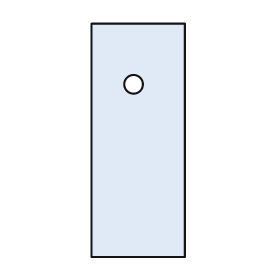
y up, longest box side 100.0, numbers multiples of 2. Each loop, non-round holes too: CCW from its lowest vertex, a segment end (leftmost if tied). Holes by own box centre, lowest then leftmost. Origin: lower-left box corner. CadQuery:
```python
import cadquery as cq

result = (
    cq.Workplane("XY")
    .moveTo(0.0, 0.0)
    .lineTo(40.0, 0.0)
    .lineTo(40.0, 100.0)
    .lineTo(0.0, 100.0)
    .close()
    .moveTo(18.0, 74.0)
    .circle(4.0)
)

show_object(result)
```